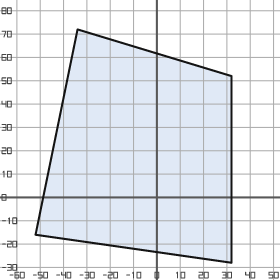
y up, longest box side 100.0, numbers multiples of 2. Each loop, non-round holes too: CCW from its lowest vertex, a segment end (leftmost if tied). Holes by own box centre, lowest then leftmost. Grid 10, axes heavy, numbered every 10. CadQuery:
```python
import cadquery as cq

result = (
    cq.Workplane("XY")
    .moveTo(32.0, -28.0)
    .lineTo(32.0, 52.0)
    .lineTo(-34.0, 72.0)
    .lineTo(-52.0, -16.0)
    .close()
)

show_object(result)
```